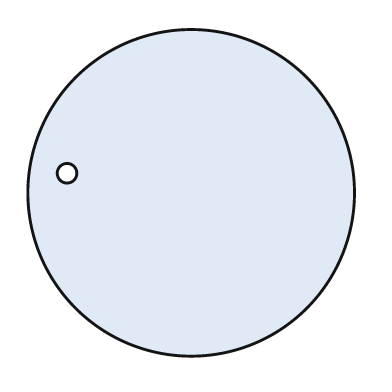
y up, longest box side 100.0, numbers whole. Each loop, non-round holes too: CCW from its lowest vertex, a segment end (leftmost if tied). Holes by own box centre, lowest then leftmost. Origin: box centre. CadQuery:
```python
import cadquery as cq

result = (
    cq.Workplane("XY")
    .moveTo(0.0, 0.0)
    .circle(50.0)
    .moveTo(-38.0, 6.0)
    .circle(3.0)
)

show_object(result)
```